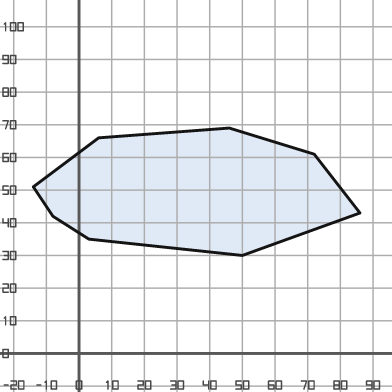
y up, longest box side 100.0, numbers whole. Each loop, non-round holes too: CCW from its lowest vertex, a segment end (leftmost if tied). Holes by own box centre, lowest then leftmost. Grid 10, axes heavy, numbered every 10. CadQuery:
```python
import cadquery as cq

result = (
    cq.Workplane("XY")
    .moveTo(50.0, 30.0)
    .lineTo(86.0, 43.0)
    .lineTo(72.0, 61.0)
    .lineTo(46.0, 69.0)
    .lineTo(6.0, 66.0)
    .lineTo(-14.0, 51.0)
    .lineTo(-8.0, 42.0)
    .lineTo(3.0, 35.0)
    .close()
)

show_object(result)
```